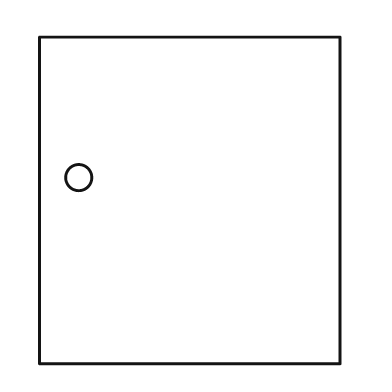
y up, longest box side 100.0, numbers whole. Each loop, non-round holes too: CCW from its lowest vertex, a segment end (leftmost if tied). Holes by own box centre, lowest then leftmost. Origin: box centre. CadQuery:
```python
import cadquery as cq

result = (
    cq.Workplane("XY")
    .moveTo(-46.0, -50.0)
    .lineTo(46.0, -50.0)
    .lineTo(46.0, 50.0)
    .lineTo(-46.0, 50.0)
    .close()
    .moveTo(-34.0, 7.0)
    .circle(4.0)
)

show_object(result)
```